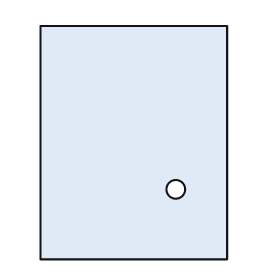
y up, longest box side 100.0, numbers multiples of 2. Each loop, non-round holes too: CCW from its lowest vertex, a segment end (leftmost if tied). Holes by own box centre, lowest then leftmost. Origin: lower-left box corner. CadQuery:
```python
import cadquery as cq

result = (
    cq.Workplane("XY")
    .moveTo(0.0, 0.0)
    .lineTo(80.0, 0.0)
    .lineTo(80.0, 100.0)
    .lineTo(0.0, 100.0)
    .close()
    .moveTo(58.0, 30.0)
    .circle(4.0)
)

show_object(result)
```